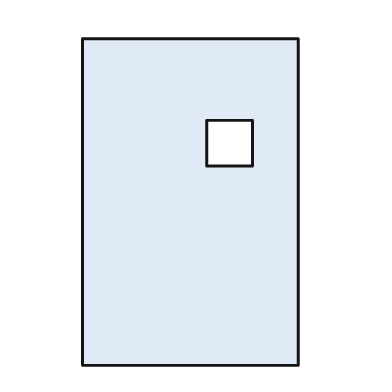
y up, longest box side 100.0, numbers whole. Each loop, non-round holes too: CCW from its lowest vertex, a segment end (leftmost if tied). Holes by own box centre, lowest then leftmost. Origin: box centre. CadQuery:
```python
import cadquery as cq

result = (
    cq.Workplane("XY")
    .moveTo(-33.0, -50.0)
    .lineTo(33.0, -50.0)
    .lineTo(33.0, 50.0)
    .lineTo(-33.0, 50.0)
    .close()
    .moveTo(5.0, 11.0)
    .lineTo(19.0, 11.0)
    .lineTo(19.0, 25.0)
    .lineTo(5.0, 25.0)
    .close()
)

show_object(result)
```